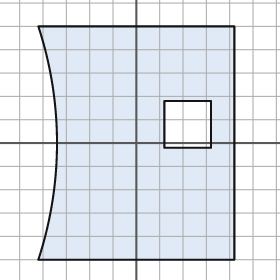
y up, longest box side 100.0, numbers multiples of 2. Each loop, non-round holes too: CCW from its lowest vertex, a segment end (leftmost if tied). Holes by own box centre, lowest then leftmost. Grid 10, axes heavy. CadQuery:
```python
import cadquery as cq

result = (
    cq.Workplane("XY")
    .moveTo(-42.0, -50.0)
    .lineTo(42.0, -50.0)
    .lineTo(42.0, 50.0)
    .lineTo(-42.0, 50.0)
    .threePointArc((-34.0, 0.0), (-42.0, -50.0))
    .close()
    .moveTo(12.0, -2.0)
    .lineTo(32.0, -2.0)
    .lineTo(32.0, 18.0)
    .lineTo(12.0, 18.0)
    .close()
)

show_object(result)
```